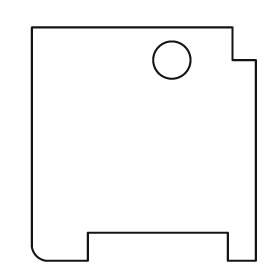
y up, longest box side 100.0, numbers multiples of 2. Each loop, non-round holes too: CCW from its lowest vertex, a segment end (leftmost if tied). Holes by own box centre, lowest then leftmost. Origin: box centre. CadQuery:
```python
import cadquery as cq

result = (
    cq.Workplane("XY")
    .moveTo(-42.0, -50.0)
    .lineTo(-24.0, -50.0)
    .lineTo(-24.0, -38.0)
    .lineTo(36.0, -38.0)
    .lineTo(36.0, -50.0)
    .lineTo(48.0, -50.0)
    .lineTo(48.0, 36.0)
    .lineTo(38.0, 36.0)
    .lineTo(38.0, 50.0)
    .lineTo(-48.0, 50.0)
    .lineTo(-48.0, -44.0)
    .threePointArc((-46.0, -48.0), (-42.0, -50.0))
    .close()
    .moveTo(12.0, 36.0)
    .circle(8.0)
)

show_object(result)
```